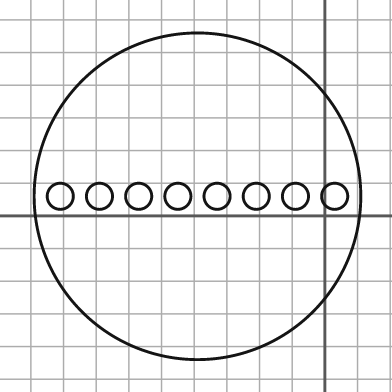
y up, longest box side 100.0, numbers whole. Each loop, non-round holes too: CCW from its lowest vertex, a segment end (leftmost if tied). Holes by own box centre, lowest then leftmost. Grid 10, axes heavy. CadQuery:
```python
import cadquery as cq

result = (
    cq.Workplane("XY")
    .moveTo(-39.0, 6.0)
    .circle(50.0)
    .moveTo(-81.0, 6.0)
    .circle(4.0)
    .moveTo(-69.0, 6.0)
    .circle(4.0)
    .moveTo(-57.0, 6.0)
    .circle(4.0)
    .moveTo(-45.0, 6.0)
    .circle(4.0)
    .moveTo(-33.0, 6.0)
    .circle(4.0)
    .moveTo(-21.0, 6.0)
    .circle(4.0)
    .moveTo(-9.0, 6.0)
    .circle(4.0)
    .moveTo(3.0, 6.0)
    .circle(4.0)
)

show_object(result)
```